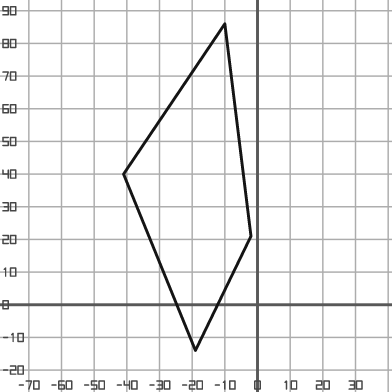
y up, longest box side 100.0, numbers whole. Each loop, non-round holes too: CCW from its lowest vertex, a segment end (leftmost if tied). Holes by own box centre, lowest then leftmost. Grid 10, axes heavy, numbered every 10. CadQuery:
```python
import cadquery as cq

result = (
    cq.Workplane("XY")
    .moveTo(-19.0, -14.0)
    .lineTo(-2.0, 21.0)
    .lineTo(-10.0, 86.0)
    .lineTo(-41.0, 40.0)
    .close()
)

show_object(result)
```